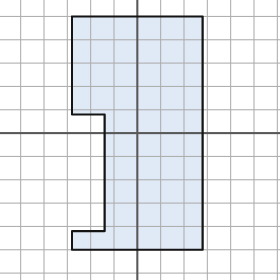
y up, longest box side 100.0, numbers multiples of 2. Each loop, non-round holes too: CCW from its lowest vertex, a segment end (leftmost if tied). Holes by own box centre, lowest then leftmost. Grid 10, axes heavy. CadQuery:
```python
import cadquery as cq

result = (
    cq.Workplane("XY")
    .moveTo(-28.0, -50.0)
    .lineTo(28.0, -50.0)
    .lineTo(28.0, 50.0)
    .lineTo(-28.0, 50.0)
    .lineTo(-28.0, 8.0)
    .lineTo(-14.0, 8.0)
    .lineTo(-14.0, -42.0)
    .lineTo(-28.0, -42.0)
    .close()
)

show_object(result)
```